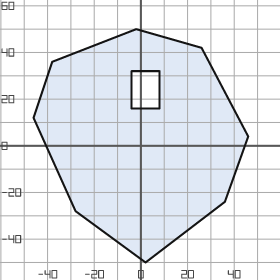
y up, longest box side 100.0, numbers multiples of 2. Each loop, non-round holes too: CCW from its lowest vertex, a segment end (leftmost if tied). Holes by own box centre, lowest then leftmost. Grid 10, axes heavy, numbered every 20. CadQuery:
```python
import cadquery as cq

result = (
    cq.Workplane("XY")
    .moveTo(2.0, -50.0)
    .lineTo(36.0, -24.0)
    .lineTo(46.0, 4.0)
    .lineTo(26.0, 42.0)
    .lineTo(-2.0, 50.0)
    .lineTo(-38.0, 36.0)
    .lineTo(-46.0, 12.0)
    .lineTo(-28.0, -28.0)
    .close()
    .moveTo(-4.0, 16.0)
    .lineTo(8.0, 16.0)
    .lineTo(8.0, 32.0)
    .lineTo(-4.0, 32.0)
    .close()
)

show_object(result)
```